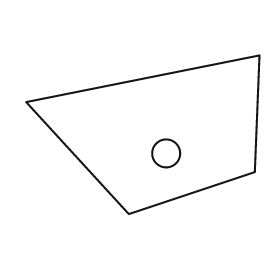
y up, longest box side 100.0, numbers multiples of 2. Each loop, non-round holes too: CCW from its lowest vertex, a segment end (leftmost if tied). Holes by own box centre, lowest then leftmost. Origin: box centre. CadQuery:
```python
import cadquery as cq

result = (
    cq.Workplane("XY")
    .moveTo(-6.0, -34.0)
    .lineTo(48.0, -16.0)
    .lineTo(50.0, 34.0)
    .lineTo(-50.0, 14.0)
    .close()
    .moveTo(10.0, -8.0)
    .circle(6.0)
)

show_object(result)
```